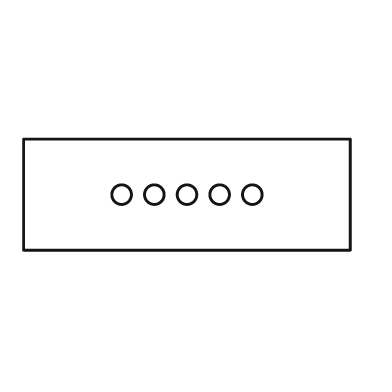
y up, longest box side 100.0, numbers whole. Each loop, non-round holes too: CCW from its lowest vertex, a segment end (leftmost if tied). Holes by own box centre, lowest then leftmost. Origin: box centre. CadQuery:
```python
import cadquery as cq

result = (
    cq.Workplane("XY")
    .moveTo(-50.0, -17.0)
    .lineTo(50.0, -17.0)
    .lineTo(50.0, 17.0)
    .lineTo(-50.0, 17.0)
    .close()
    .moveTo(-20.0, 0.0)
    .circle(3.0)
    .moveTo(-10.0, 0.0)
    .circle(3.0)
    .moveTo(0.0, 0.0)
    .circle(3.0)
    .moveTo(10.0, 0.0)
    .circle(3.0)
    .moveTo(20.0, 0.0)
    .circle(3.0)
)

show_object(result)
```